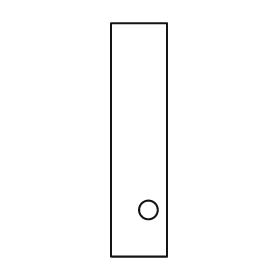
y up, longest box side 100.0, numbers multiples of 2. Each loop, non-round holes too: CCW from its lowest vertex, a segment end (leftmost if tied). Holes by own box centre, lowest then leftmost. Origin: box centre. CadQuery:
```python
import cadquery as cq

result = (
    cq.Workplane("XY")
    .moveTo(-12.0, -50.0)
    .lineTo(12.0, -50.0)
    .lineTo(12.0, 50.0)
    .lineTo(-12.0, 50.0)
    .close()
    .moveTo(4.0, -30.0)
    .circle(4.0)
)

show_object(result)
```